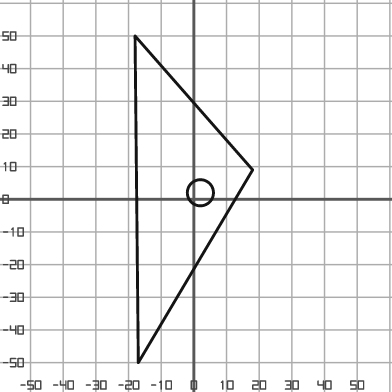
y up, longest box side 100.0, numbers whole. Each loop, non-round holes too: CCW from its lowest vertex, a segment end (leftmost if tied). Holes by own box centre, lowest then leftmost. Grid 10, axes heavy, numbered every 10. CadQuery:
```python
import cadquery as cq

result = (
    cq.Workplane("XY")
    .moveTo(-17.0, -50.0)
    .lineTo(18.0, 9.0)
    .lineTo(-18.0, 50.0)
    .close()
    .moveTo(2.0, 2.0)
    .circle(4.0)
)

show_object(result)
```